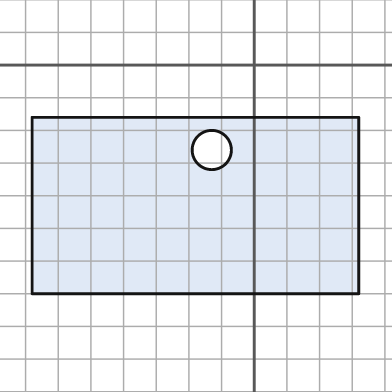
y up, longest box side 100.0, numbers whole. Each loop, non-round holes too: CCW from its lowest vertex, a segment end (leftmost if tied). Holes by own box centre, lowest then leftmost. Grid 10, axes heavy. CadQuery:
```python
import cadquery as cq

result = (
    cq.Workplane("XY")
    .moveTo(-68.0, -70.0)
    .lineTo(32.0, -70.0)
    .lineTo(32.0, -16.0)
    .lineTo(-68.0, -16.0)
    .close()
    .moveTo(-13.0, -26.0)
    .circle(6.0)
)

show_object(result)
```